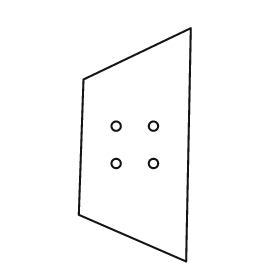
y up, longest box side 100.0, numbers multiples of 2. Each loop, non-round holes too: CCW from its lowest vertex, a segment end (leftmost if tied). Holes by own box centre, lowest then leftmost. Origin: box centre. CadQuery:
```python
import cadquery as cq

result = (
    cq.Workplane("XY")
    .moveTo(22.0, -50.0)
    .lineTo(24.0, 50.0)
    .lineTo(-22.0, 28.0)
    .lineTo(-24.0, -30.0)
    .close()
    .moveTo(-8.0, -8.0)
    .circle(2.0)
    .moveTo(8.0, -8.0)
    .circle(2.0)
    .moveTo(-8.0, 8.0)
    .circle(2.0)
    .moveTo(8.0, 8.0)
    .circle(2.0)
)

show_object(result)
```